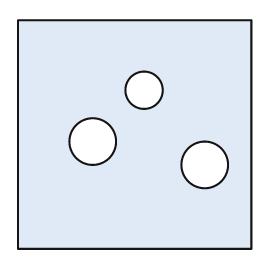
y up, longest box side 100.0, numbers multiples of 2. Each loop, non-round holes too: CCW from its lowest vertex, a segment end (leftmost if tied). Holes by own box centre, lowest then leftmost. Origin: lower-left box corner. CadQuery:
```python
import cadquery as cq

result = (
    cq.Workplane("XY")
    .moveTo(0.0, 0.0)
    .lineTo(100.0, 0.0)
    .lineTo(100.0, 98.0)
    .lineTo(0.0, 98.0)
    .close()
    .moveTo(80.0, 36.0)
    .circle(10.0)
    .moveTo(32.0, 46.0)
    .circle(10.0)
    .moveTo(54.0, 68.0)
    .circle(8.0)
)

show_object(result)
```